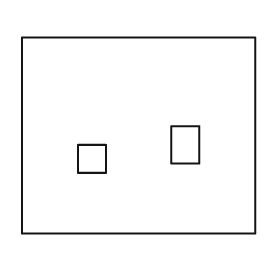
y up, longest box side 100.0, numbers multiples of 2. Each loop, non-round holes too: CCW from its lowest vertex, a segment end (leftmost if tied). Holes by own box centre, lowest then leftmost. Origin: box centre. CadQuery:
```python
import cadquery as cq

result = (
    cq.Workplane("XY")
    .moveTo(-50.0, -42.0)
    .lineTo(50.0, -42.0)
    .lineTo(50.0, 42.0)
    .lineTo(-50.0, 42.0)
    .close()
    .moveTo(-26.0, -16.0)
    .lineTo(-14.0, -16.0)
    .lineTo(-14.0, -4.0)
    .lineTo(-26.0, -4.0)
    .close()
    .moveTo(14.0, -12.0)
    .lineTo(26.0, -12.0)
    .lineTo(26.0, 4.0)
    .lineTo(14.0, 4.0)
    .close()
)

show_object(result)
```